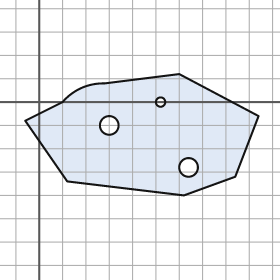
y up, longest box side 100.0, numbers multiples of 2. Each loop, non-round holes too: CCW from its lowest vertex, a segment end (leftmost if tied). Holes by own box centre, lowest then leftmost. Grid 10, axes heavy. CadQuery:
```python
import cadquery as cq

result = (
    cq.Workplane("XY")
    .moveTo(62.0, -40.0)
    .lineTo(84.0, -32.0)
    .lineTo(94.0, -6.0)
    .lineTo(60.0, 12.0)
    .lineTo(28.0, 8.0)
    .threePointArc((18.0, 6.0), (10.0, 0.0))
    .lineTo(-6.0, -8.0)
    .lineTo(12.0, -34.0)
    .close()
    .moveTo(64.0, -28.0)
    .circle(4.0)
    .moveTo(30.0, -10.0)
    .circle(4.0)
    .moveTo(52.0, 0.0)
    .circle(2.0)
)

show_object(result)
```